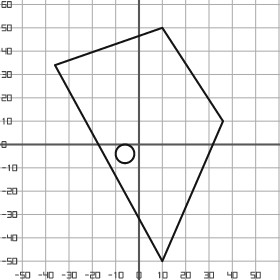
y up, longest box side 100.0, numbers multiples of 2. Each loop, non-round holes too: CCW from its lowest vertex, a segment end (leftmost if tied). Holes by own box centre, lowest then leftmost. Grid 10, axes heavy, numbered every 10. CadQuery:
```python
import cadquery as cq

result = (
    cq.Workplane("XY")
    .moveTo(10.0, -50.0)
    .lineTo(36.0, 10.0)
    .lineTo(10.0, 50.0)
    .lineTo(-36.0, 34.0)
    .close()
    .moveTo(-6.0, -4.0)
    .circle(4.0)
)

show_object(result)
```